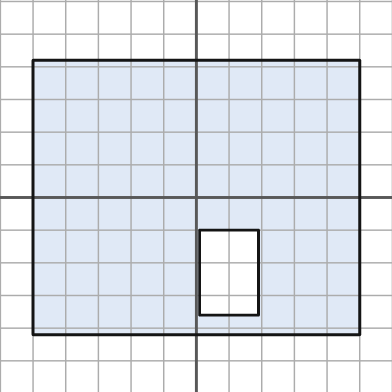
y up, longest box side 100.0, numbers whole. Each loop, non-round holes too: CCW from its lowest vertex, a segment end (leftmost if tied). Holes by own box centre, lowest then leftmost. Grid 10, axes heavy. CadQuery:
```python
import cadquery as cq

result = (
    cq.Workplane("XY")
    .moveTo(-50.0, -42.0)
    .lineTo(50.0, -42.0)
    .lineTo(50.0, 42.0)
    .lineTo(-50.0, 42.0)
    .close()
    .moveTo(1.0, -36.0)
    .lineTo(19.0, -36.0)
    .lineTo(19.0, -10.0)
    .lineTo(1.0, -10.0)
    .close()
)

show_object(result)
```